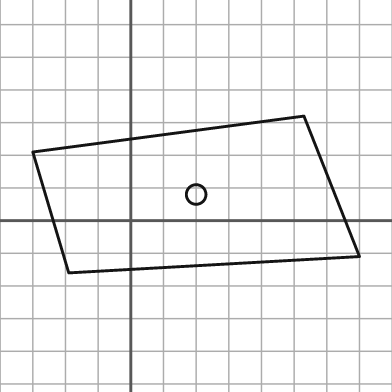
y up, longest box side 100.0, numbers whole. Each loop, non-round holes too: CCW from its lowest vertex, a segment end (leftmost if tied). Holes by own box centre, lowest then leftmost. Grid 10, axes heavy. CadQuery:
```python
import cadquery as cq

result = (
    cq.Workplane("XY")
    .moveTo(-19.0, -16.0)
    .lineTo(70.0, -11.0)
    .lineTo(53.0, 32.0)
    .lineTo(-30.0, 21.0)
    .close()
    .moveTo(20.0, 8.0)
    .circle(3.0)
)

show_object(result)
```